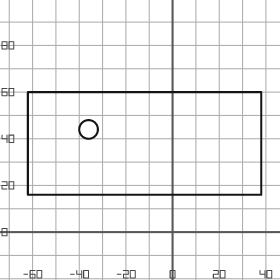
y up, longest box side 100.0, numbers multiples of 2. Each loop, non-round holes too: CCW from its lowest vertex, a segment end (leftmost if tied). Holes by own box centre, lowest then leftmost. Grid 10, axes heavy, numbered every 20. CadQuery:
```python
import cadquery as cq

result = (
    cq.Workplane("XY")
    .moveTo(-62.0, 16.0)
    .lineTo(38.0, 16.0)
    .lineTo(38.0, 60.0)
    .lineTo(-62.0, 60.0)
    .close()
    .moveTo(-36.0, 44.0)
    .circle(4.0)
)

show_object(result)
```